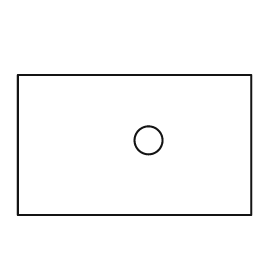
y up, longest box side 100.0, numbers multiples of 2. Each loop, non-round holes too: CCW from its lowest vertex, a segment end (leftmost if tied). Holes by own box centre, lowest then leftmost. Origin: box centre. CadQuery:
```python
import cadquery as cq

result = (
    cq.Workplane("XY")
    .moveTo(-50.0, -30.0)
    .lineTo(50.0, -30.0)
    .lineTo(50.0, 30.0)
    .lineTo(-50.0, 30.0)
    .close()
    .moveTo(6.0, 2.0)
    .circle(6.0)
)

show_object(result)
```